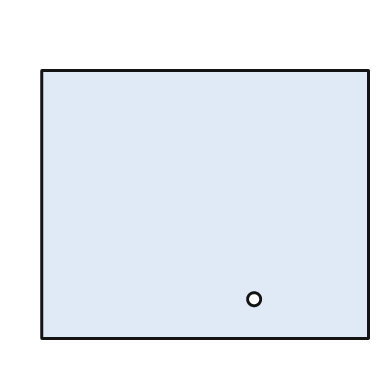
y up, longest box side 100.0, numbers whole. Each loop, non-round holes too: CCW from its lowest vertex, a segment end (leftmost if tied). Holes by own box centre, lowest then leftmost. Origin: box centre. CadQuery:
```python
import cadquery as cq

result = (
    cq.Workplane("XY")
    .moveTo(-50.0, -41.0)
    .lineTo(50.0, -41.0)
    .lineTo(50.0, 41.0)
    .lineTo(-50.0, 41.0)
    .close()
    .moveTo(15.0, -29.0)
    .circle(2.0)
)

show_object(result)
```